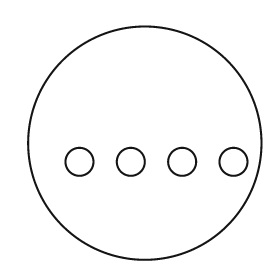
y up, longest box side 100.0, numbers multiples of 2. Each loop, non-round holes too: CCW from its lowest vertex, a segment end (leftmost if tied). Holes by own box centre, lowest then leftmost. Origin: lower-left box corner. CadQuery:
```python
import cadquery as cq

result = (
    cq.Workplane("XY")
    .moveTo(50.0, 50.0)
    .circle(50.0)
    .moveTo(22.0, 42.0)
    .circle(6.0)
    .moveTo(44.0, 42.0)
    .circle(6.0)
    .moveTo(66.0, 42.0)
    .circle(6.0)
    .moveTo(88.0, 42.0)
    .circle(6.0)
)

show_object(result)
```